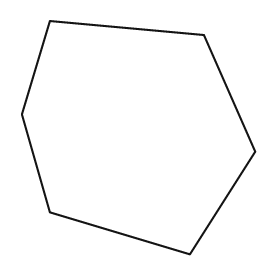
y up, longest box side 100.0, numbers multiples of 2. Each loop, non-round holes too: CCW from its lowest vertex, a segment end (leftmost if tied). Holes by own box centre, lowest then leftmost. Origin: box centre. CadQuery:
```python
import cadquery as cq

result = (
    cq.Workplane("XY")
    .moveTo(22.0, -50.0)
    .lineTo(50.0, -6.0)
    .lineTo(28.0, 44.0)
    .lineTo(-38.0, 50.0)
    .lineTo(-50.0, 10.0)
    .lineTo(-38.0, -32.0)
    .close()
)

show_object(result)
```